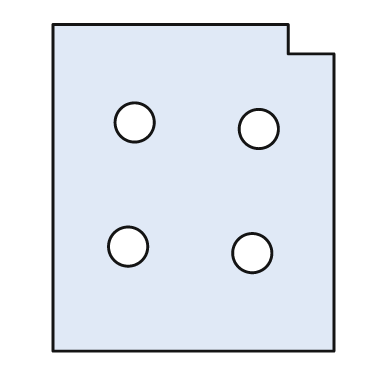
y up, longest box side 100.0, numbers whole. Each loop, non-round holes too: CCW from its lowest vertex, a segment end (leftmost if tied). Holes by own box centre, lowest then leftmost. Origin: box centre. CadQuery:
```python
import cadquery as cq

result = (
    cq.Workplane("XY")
    .moveTo(-43.0, -50.0)
    .lineTo(43.0, -50.0)
    .lineTo(43.0, 41.0)
    .lineTo(29.0, 41.0)
    .lineTo(29.0, 50.0)
    .lineTo(-43.0, 50.0)
    .close()
    .moveTo(18.0, -20.0)
    .circle(6.0)
    .moveTo(-20.0, -18.0)
    .circle(6.0)
    .moveTo(20.0, 18.0)
    .circle(6.0)
    .moveTo(-18.0, 20.0)
    .circle(6.0)
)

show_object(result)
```